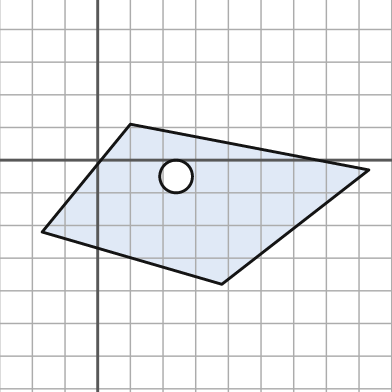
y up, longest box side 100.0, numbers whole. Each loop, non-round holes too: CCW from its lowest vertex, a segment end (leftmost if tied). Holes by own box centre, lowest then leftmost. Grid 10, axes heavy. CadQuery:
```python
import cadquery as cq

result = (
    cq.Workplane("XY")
    .moveTo(38.0, -38.0)
    .lineTo(83.0, -3.0)
    .lineTo(10.0, 11.0)
    .lineTo(-17.0, -22.0)
    .close()
    .moveTo(24.0, -5.0)
    .circle(5.0)
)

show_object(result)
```